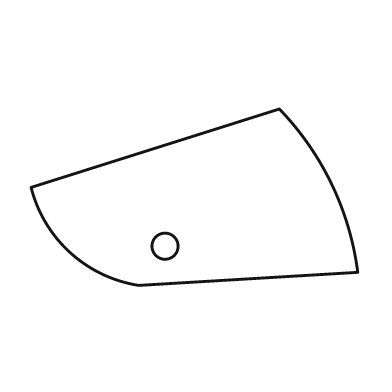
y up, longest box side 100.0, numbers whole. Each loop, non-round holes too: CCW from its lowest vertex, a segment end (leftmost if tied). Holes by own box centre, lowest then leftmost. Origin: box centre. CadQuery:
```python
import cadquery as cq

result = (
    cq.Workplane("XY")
    .moveTo(-17.0, -27.0)
    .lineTo(50.0, -23.0)
    .threePointArc((42.0, 4.0), (26.0, 27.0))
    .lineTo(-50.0, 3.0)
    .threePointArc((-38.0, -17.0), (-17.0, -27.0))
    .close()
    .moveTo(-9.0, -15.0)
    .circle(4.0)
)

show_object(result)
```